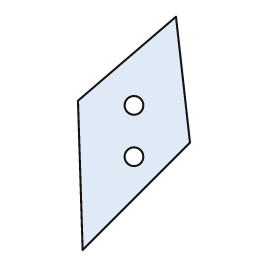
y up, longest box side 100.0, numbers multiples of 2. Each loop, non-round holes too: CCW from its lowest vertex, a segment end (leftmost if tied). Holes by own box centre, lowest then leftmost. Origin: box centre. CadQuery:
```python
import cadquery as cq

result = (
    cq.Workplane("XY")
    .moveTo(-22.0, -50.0)
    .lineTo(24.0, -4.0)
    .lineTo(18.0, 50.0)
    .lineTo(-24.0, 14.0)
    .close()
    .moveTo(0.0, -10.0)
    .circle(4.0)
    .moveTo(0.0, 12.0)
    .circle(4.0)
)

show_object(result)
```